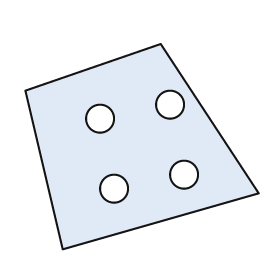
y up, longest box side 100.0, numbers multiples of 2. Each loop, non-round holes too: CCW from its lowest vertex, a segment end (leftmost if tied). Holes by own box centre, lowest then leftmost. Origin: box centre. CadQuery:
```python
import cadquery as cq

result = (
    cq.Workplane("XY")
    .moveTo(-34.0, -44.0)
    .lineTo(50.0, -20.0)
    .lineTo(8.0, 44.0)
    .lineTo(-50.0, 24.0)
    .close()
    .moveTo(-12.0, -18.0)
    .circle(6.0)
    .moveTo(18.0, -12.0)
    .circle(6.0)
    .moveTo(-18.0, 12.0)
    .circle(6.0)
    .moveTo(12.0, 18.0)
    .circle(6.0)
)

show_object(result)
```